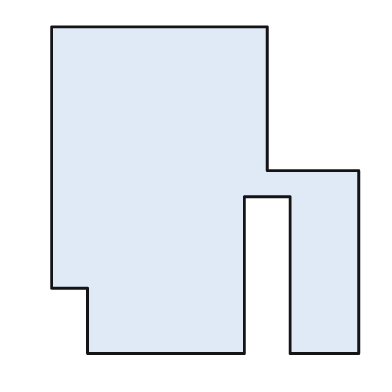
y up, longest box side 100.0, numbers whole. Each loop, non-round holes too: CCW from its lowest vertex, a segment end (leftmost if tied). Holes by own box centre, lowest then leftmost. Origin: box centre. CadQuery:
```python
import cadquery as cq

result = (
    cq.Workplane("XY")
    .moveTo(-36.0, -50.0)
    .lineTo(12.0, -50.0)
    .lineTo(12.0, -2.0)
    .lineTo(26.0, -2.0)
    .lineTo(26.0, -50.0)
    .lineTo(47.0, -50.0)
    .lineTo(47.0, 6.0)
    .lineTo(19.0, 6.0)
    .lineTo(19.0, 50.0)
    .lineTo(-47.0, 50.0)
    .lineTo(-47.0, -30.0)
    .lineTo(-36.0, -30.0)
    .close()
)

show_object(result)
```